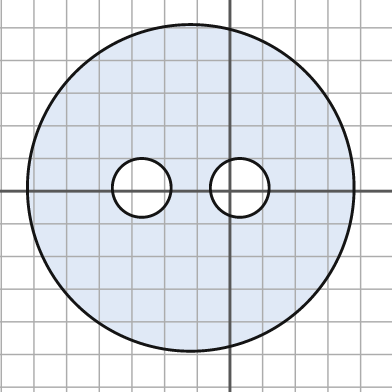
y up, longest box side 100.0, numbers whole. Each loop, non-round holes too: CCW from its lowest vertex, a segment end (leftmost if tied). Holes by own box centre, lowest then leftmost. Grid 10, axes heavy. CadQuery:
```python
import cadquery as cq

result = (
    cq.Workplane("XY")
    .moveTo(-12.0, 1.0)
    .circle(50.0)
    .moveTo(-27.0, 1.0)
    .circle(9.0)
    .moveTo(3.0, 1.0)
    .circle(9.0)
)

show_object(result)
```